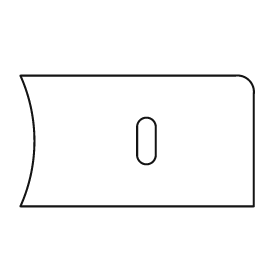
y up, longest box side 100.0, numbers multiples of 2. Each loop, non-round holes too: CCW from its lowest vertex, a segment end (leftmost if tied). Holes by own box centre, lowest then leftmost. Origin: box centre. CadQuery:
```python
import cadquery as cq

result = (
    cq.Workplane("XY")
    .moveTo(-50.0, -28.0)
    .lineTo(50.0, -28.0)
    .lineTo(50.0, 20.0)
    .threePointArc((48.0, 26.0), (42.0, 28.0))
    .lineTo(-50.0, 28.0)
    .threePointArc((-44.0, 0.0), (-50.0, -28.0))
    .close()
    .moveTo(0.0, -6.0)
    .threePointArc((4.0, -10.0), (8.0, -6.0))
    .lineTo(8.0, 6.0)
    .threePointArc((4.0, 10.0), (0.0, 6.0))
    .close()
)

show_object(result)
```